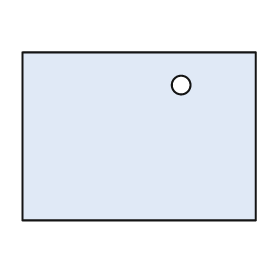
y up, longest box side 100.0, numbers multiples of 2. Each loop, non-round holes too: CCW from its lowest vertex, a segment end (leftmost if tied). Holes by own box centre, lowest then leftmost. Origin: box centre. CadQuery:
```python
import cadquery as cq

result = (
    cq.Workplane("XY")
    .moveTo(-50.0, -36.0)
    .lineTo(50.0, -36.0)
    .lineTo(50.0, 36.0)
    .lineTo(-50.0, 36.0)
    .close()
    .moveTo(18.0, 22.0)
    .circle(4.0)
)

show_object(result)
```